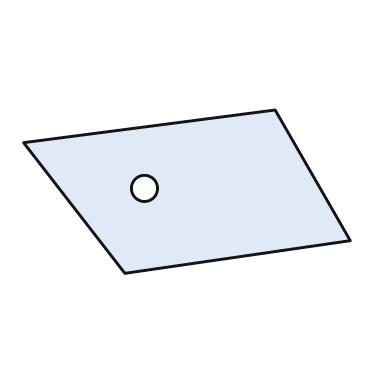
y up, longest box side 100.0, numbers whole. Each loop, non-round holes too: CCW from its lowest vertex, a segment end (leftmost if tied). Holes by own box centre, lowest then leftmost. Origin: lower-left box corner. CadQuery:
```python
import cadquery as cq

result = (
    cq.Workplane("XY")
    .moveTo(31.0, 0.0)
    .lineTo(100.0, 10.0)
    .lineTo(77.0, 50.0)
    .lineTo(0.0, 40.0)
    .close()
    .moveTo(37.0, 26.0)
    .circle(4.0)
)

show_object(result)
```